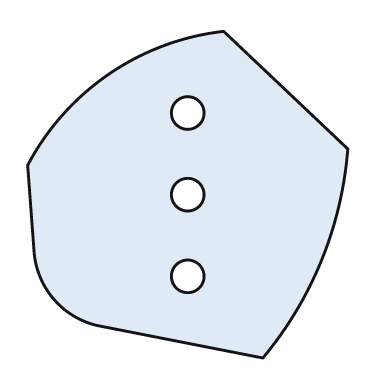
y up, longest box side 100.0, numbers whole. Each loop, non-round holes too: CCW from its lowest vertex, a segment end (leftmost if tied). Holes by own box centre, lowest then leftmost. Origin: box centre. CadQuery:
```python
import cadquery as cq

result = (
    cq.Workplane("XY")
    .moveTo(23.0, -50.0)
    .threePointArc((41.0, -20.0), (49.0, 14.0))
    .lineTo(11.0, 50.0)
    .threePointArc((-24.0, 37.0), (-49.0, 9.0))
    .lineTo(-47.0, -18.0)
    .threePointArc((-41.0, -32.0), (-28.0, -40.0))
    .close()
    .moveTo(0.0, -25.0)
    .circle(5.0)
    .moveTo(0.0, 0.0)
    .circle(5.0)
    .moveTo(0.0, 25.0)
    .circle(5.0)
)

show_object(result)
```